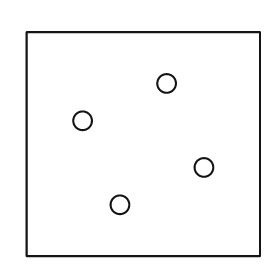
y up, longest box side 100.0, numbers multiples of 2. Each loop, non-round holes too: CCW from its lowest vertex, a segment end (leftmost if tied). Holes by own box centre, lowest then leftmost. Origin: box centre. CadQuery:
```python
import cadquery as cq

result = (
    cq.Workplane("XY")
    .moveTo(-50.0, -48.0)
    .lineTo(50.0, -48.0)
    .lineTo(50.0, 48.0)
    .lineTo(-50.0, 48.0)
    .close()
    .moveTo(-10.0, -26.0)
    .circle(4.0)
    .moveTo(26.0, -10.0)
    .circle(4.0)
    .moveTo(-26.0, 10.0)
    .circle(4.0)
    .moveTo(10.0, 26.0)
    .circle(4.0)
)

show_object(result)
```